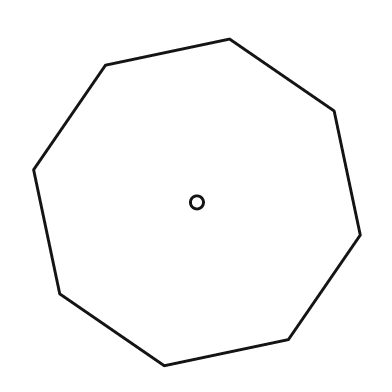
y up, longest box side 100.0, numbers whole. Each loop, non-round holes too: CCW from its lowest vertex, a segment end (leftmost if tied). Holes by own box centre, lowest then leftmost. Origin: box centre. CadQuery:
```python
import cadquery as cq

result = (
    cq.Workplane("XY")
    .moveTo(-10.0, -50.0)
    .lineTo(28.0, -42.0)
    .lineTo(50.0, -10.0)
    .lineTo(42.0, 28.0)
    .lineTo(10.0, 50.0)
    .lineTo(-28.0, 42.0)
    .lineTo(-50.0, 10.0)
    .lineTo(-42.0, -28.0)
    .close()
    .moveTo(0.0, 0.0)
    .circle(2.0)
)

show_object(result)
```